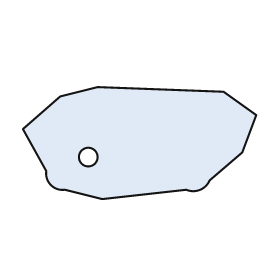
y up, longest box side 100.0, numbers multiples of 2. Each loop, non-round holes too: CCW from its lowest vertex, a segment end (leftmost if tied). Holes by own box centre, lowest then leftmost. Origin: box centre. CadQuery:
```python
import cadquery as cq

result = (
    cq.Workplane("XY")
    .moveTo(-16.0, -24.0)
    .lineTo(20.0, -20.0)
    .threePointArc((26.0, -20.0), (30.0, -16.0))
    .lineTo(44.0, -4.0)
    .lineTo(50.0, 12.0)
    .lineTo(36.0, 22.0)
    .lineTo(-18.0, 24.0)
    .lineTo(-34.0, 20.0)
    .lineTo(-50.0, 6.0)
    .lineTo(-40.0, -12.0)
    .threePointArc((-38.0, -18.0), (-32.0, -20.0))
    .close()
    .moveTo(-22.0, -6.0)
    .circle(4.0)
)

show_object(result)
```